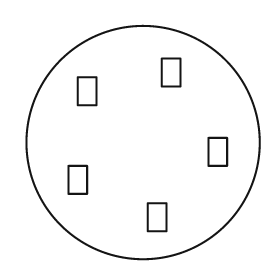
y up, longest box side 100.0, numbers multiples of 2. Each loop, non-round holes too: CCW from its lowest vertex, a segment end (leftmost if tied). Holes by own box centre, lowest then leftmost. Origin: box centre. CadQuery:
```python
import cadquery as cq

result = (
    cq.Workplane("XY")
    .moveTo(0.0, 0.0)
    .circle(50.0)
    .moveTo(2.0, -38.0)
    .lineTo(10.0, -38.0)
    .lineTo(10.0, -26.0)
    .lineTo(2.0, -26.0)
    .close()
    .moveTo(-32.0, -22.0)
    .lineTo(-24.0, -22.0)
    .lineTo(-24.0, -10.0)
    .lineTo(-32.0, -10.0)
    .close()
    .moveTo(28.0, -10.0)
    .lineTo(36.0, -10.0)
    .lineTo(36.0, 2.0)
    .lineTo(28.0, 2.0)
    .close()
    .moveTo(-28.0, 16.0)
    .lineTo(-20.0, 16.0)
    .lineTo(-20.0, 28.0)
    .lineTo(-28.0, 28.0)
    .close()
    .moveTo(8.0, 24.0)
    .lineTo(16.0, 24.0)
    .lineTo(16.0, 36.0)
    .lineTo(8.0, 36.0)
    .close()
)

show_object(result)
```